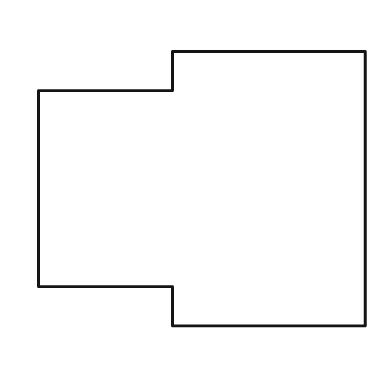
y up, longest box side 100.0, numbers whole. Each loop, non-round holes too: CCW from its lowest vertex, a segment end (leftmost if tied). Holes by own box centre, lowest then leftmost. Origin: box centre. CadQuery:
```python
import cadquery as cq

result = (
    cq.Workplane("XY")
    .moveTo(-9.0, -42.0)
    .lineTo(50.0, -42.0)
    .lineTo(50.0, 42.0)
    .lineTo(-9.0, 42.0)
    .lineTo(-9.0, 30.0)
    .lineTo(-50.0, 30.0)
    .lineTo(-50.0, -30.0)
    .lineTo(-9.0, -30.0)
    .close()
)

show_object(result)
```